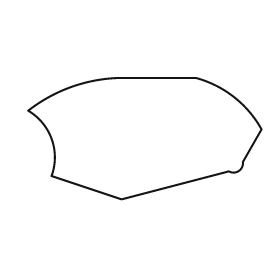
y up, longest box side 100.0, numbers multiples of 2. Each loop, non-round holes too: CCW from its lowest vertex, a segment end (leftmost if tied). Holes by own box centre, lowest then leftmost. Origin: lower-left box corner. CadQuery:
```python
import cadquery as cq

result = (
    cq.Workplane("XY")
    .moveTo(40.0, 0.0)
    .lineTo(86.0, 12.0)
    .threePointArc((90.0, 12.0), (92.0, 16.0))
    .lineTo(100.0, 30.0)
    .threePointArc((88.0, 44.0), (72.0, 52.0))
    .lineTo(38.0, 52.0)
    .threePointArc((18.0, 48.0), (0.0, 38.0))
    .threePointArc((10.0, 26.0), (10.0, 10.0))
    .close()
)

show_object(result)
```